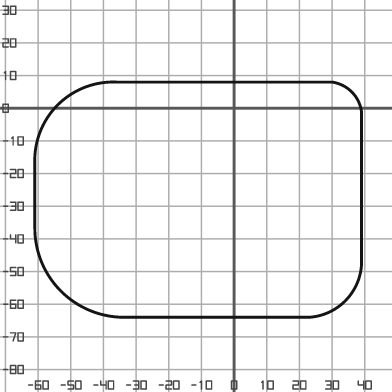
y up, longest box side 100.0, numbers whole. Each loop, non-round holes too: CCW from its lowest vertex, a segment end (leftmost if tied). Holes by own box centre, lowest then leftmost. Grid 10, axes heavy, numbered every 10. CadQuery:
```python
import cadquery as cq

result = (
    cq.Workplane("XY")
    .moveTo(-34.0, -64.0)
    .lineTo(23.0, -64.0)
    .threePointArc((34.0, -59.0), (39.0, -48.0))
    .lineTo(39.0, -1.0)
    .threePointArc((36.0, 5.0), (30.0, 8.0))
    .lineTo(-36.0, 8.0)
    .threePointArc((-54.0, 1.0), (-61.0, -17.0))
    .lineTo(-61.0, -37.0)
    .threePointArc((-53.0, -56.0), (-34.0, -64.0))
    .close()
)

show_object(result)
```